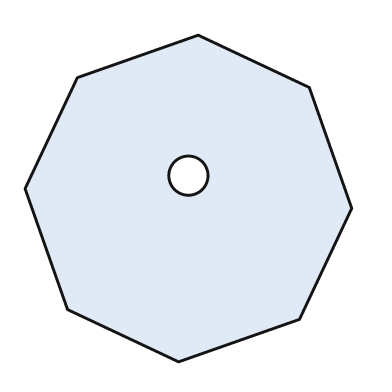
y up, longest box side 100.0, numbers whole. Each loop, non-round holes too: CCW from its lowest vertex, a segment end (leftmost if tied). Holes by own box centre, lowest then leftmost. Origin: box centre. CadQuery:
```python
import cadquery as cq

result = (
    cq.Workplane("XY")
    .moveTo(-3.0, -50.0)
    .lineTo(34.0, -37.0)
    .lineTo(50.0, -3.0)
    .lineTo(37.0, 34.0)
    .lineTo(3.0, 50.0)
    .lineTo(-34.0, 37.0)
    .lineTo(-50.0, 3.0)
    .lineTo(-37.0, -34.0)
    .close()
    .moveTo(0.0, 7.0)
    .circle(6.0)
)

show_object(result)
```